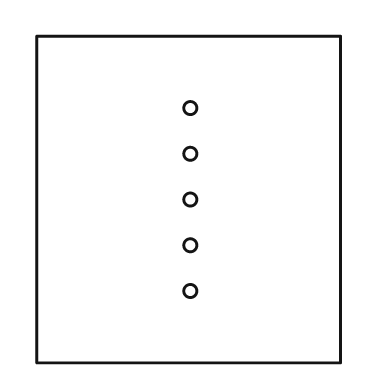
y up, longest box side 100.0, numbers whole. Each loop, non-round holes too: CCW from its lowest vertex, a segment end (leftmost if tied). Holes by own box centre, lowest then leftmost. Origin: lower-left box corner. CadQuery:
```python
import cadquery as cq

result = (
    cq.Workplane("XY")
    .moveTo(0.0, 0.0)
    .lineTo(93.0, 0.0)
    .lineTo(93.0, 100.0)
    .lineTo(0.0, 100.0)
    .close()
    .moveTo(47.0, 22.0)
    .circle(2.0)
    .moveTo(47.0, 36.0)
    .circle(2.0)
    .moveTo(47.0, 50.0)
    .circle(2.0)
    .moveTo(47.0, 64.0)
    .circle(2.0)
    .moveTo(47.0, 78.0)
    .circle(2.0)
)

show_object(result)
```